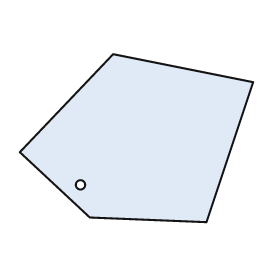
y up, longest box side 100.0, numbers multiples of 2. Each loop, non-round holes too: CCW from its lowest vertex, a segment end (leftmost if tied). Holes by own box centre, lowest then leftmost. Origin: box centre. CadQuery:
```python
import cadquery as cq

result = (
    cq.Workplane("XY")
    .moveTo(30.0, -36.0)
    .lineTo(50.0, 24.0)
    .lineTo(-10.0, 36.0)
    .lineTo(-50.0, -6.0)
    .lineTo(-20.0, -34.0)
    .close()
    .moveTo(-24.0, -20.0)
    .circle(2.0)
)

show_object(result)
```